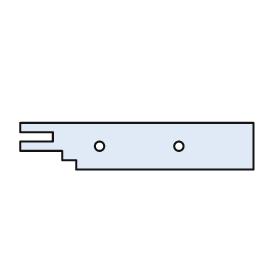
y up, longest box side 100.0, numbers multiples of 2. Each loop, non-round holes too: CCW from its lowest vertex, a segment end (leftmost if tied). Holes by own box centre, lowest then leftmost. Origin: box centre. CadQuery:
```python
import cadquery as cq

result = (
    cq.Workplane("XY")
    .moveTo(-26.0, -10.0)
    .lineTo(50.0, -10.0)
    .lineTo(50.0, 10.0)
    .lineTo(-50.0, 10.0)
    .lineTo(-50.0, 6.0)
    .lineTo(-36.0, 6.0)
    .lineTo(-36.0, 2.0)
    .lineTo(-50.0, 2.0)
    .lineTo(-50.0, -2.0)
    .lineTo(-32.0, -2.0)
    .lineTo(-32.0, -6.0)
    .lineTo(-26.0, -6.0)
    .close()
    .moveTo(-16.0, 0.0)
    .circle(2.0)
    .moveTo(18.0, 0.0)
    .circle(2.0)
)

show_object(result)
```